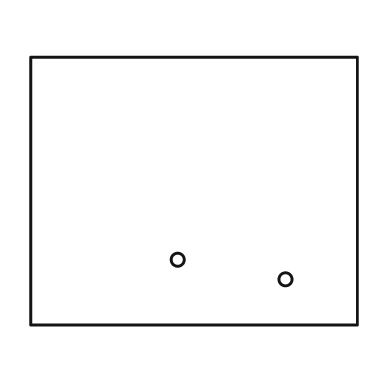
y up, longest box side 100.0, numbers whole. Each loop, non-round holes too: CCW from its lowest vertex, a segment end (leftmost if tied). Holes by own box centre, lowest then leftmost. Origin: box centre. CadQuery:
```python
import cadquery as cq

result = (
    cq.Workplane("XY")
    .moveTo(-50.0, -41.0)
    .lineTo(50.0, -41.0)
    .lineTo(50.0, 41.0)
    .lineTo(-50.0, 41.0)
    .close()
    .moveTo(28.0, -27.0)
    .circle(2.0)
    .moveTo(-5.0, -21.0)
    .circle(2.0)
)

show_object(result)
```